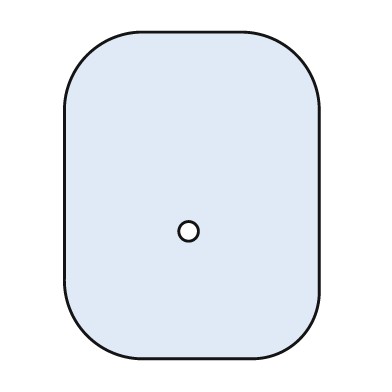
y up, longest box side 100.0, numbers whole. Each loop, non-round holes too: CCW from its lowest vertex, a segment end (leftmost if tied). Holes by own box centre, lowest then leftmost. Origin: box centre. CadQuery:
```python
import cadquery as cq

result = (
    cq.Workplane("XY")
    .moveTo(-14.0, -50.0)
    .lineTo(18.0, -50.0)
    .threePointArc((33.0, -44.0), (39.0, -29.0))
    .lineTo(39.0, 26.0)
    .threePointArc((32.0, 43.0), (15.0, 50.0))
    .lineTo(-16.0, 50.0)
    .threePointArc((-32.0, 43.0), (-39.0, 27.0))
    .lineTo(-39.0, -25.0)
    .threePointArc((-32.0, -43.0), (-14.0, -50.0))
    .close()
    .moveTo(-1.0, -11.0)
    .circle(3.0)
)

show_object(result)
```